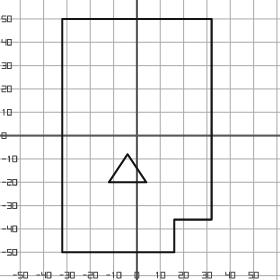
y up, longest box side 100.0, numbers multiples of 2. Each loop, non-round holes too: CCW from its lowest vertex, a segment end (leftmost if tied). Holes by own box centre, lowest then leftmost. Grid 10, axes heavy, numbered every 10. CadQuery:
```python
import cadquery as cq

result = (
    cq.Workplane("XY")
    .moveTo(-32.0, -50.0)
    .lineTo(16.0, -50.0)
    .lineTo(16.0, -36.0)
    .lineTo(32.0, -36.0)
    .lineTo(32.0, 50.0)
    .lineTo(-32.0, 50.0)
    .close()
    .moveTo(-12.0, -20.0)
    .lineTo(4.0, -20.0)
    .lineTo(-4.0, -8.0)
    .close()
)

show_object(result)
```